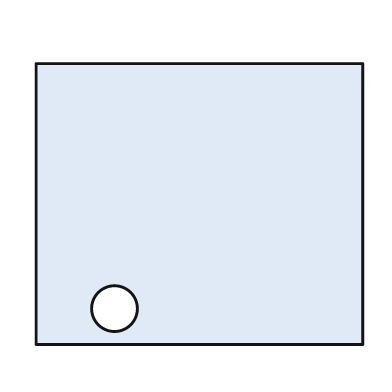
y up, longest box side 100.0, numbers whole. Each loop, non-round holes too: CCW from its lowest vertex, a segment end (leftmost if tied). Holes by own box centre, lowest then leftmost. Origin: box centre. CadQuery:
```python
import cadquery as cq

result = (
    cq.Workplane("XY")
    .moveTo(-50.0, -43.0)
    .lineTo(50.0, -43.0)
    .lineTo(50.0, 43.0)
    .lineTo(-50.0, 43.0)
    .close()
    .moveTo(-26.0, -32.0)
    .circle(7.0)
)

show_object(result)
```